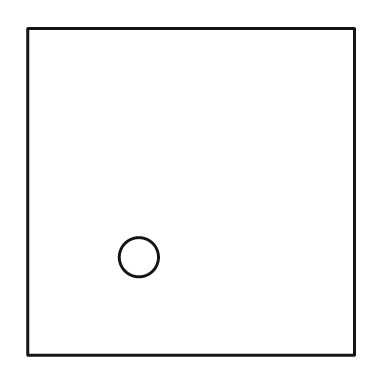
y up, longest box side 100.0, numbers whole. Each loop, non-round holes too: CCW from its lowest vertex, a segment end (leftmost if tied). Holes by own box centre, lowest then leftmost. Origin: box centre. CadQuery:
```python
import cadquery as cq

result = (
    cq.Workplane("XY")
    .moveTo(-50.0, -50.0)
    .lineTo(50.0, -50.0)
    .lineTo(50.0, 50.0)
    .lineTo(-50.0, 50.0)
    .close()
    .moveTo(-16.0, -20.0)
    .circle(6.0)
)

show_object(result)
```